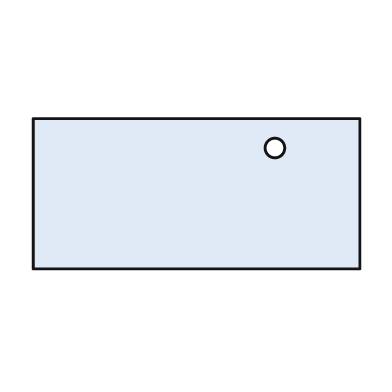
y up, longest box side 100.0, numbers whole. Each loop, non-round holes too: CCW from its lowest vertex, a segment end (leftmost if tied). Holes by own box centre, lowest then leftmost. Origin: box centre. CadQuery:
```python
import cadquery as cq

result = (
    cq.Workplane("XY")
    .moveTo(-50.0, -23.0)
    .lineTo(50.0, -23.0)
    .lineTo(50.0, 23.0)
    .lineTo(-50.0, 23.0)
    .close()
    .moveTo(24.0, 14.0)
    .circle(3.0)
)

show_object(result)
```